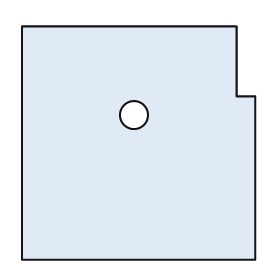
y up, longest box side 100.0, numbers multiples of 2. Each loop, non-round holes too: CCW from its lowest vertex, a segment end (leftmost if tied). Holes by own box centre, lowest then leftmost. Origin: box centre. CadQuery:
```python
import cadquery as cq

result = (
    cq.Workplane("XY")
    .moveTo(-50.0, -50.0)
    .lineTo(50.0, -50.0)
    .lineTo(50.0, 20.0)
    .lineTo(42.0, 20.0)
    .lineTo(42.0, 50.0)
    .lineTo(-50.0, 50.0)
    .close()
    .moveTo(-2.0, 12.0)
    .circle(6.0)
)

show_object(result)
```